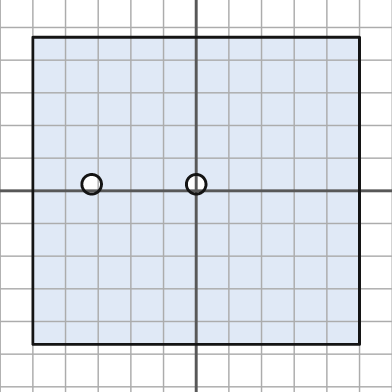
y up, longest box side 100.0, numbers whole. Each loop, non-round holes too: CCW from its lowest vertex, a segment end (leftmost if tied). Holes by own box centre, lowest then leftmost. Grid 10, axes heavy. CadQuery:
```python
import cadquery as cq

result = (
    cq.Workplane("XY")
    .moveTo(-50.0, -47.0)
    .lineTo(50.0, -47.0)
    .lineTo(50.0, 47.0)
    .lineTo(-50.0, 47.0)
    .close()
    .moveTo(-32.0, 2.0)
    .circle(3.0)
    .moveTo(0.0, 2.0)
    .circle(3.0)
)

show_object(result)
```